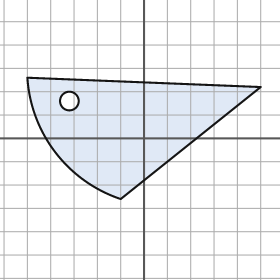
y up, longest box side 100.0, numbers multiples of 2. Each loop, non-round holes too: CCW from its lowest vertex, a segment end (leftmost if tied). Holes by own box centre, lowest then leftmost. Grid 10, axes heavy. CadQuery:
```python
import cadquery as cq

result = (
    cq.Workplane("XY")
    .moveTo(-10.0, -26.0)
    .lineTo(50.0, 22.0)
    .lineTo(-50.0, 26.0)
    .threePointArc((-38.0, -6.0), (-10.0, -26.0))
    .close()
    .moveTo(-32.0, 16.0)
    .circle(4.0)
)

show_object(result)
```